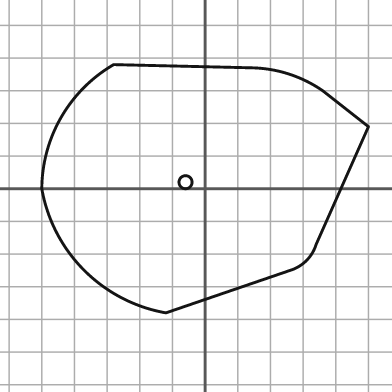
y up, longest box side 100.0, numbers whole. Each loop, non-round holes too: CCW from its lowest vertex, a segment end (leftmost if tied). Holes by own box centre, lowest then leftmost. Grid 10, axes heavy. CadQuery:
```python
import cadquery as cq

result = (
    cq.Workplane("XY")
    .moveTo(-12.0, -38.0)
    .lineTo(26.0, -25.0)
    .threePointArc((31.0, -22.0), (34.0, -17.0))
    .lineTo(50.0, 19.0)
    .lineTo(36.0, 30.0)
    .threePointArc((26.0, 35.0), (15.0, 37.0))
    .lineTo(-28.0, 38.0)
    .threePointArc((-44.0, 22.0), (-50.0, 0.0))
    .threePointArc((-37.0, -25.0), (-12.0, -38.0))
    .close()
    .moveTo(-6.0, 2.0)
    .circle(2.0)
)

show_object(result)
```